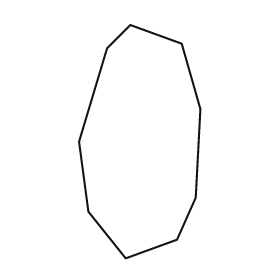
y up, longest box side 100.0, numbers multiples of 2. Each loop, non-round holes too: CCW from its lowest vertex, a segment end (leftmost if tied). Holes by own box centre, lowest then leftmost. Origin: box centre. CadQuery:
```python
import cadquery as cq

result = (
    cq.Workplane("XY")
    .moveTo(-6.0, -50.0)
    .lineTo(16.0, -42.0)
    .lineTo(24.0, -24.0)
    .lineTo(26.0, 14.0)
    .lineTo(18.0, 42.0)
    .lineTo(-4.0, 50.0)
    .lineTo(-14.0, 40.0)
    .lineTo(-26.0, 0.0)
    .lineTo(-22.0, -30.0)
    .close()
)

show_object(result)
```